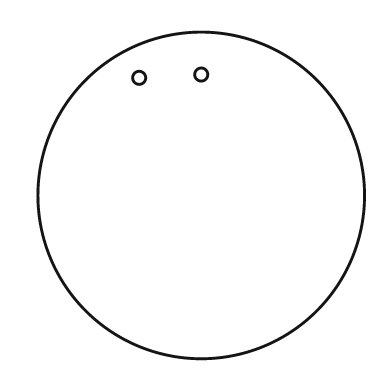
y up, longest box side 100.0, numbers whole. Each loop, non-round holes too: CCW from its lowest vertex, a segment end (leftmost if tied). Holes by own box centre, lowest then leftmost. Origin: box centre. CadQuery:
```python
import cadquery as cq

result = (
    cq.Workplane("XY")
    .moveTo(0.0, 0.0)
    .circle(50.0)
    .moveTo(-19.0, 36.0)
    .circle(2.0)
    .moveTo(0.0, 37.0)
    .circle(2.0)
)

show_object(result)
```